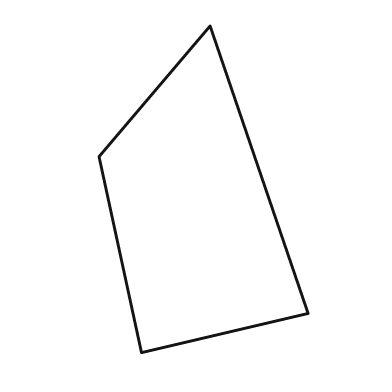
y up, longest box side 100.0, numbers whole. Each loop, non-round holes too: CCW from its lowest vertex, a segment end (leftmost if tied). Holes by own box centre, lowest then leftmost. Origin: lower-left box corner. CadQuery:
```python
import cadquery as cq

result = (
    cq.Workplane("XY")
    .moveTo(13.0, 0.0)
    .lineTo(64.0, 12.0)
    .lineTo(34.0, 100.0)
    .lineTo(0.0, 60.0)
    .close()
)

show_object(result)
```